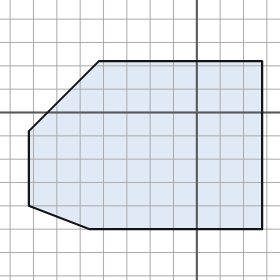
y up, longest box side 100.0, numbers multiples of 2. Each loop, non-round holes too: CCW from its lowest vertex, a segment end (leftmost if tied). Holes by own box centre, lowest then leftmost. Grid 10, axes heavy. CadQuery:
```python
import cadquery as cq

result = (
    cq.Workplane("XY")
    .moveTo(-46.0, -50.0)
    .lineTo(28.0, -50.0)
    .lineTo(28.0, 22.0)
    .lineTo(-42.0, 22.0)
    .lineTo(-72.0, -8.0)
    .lineTo(-72.0, -40.0)
    .close()
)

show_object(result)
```